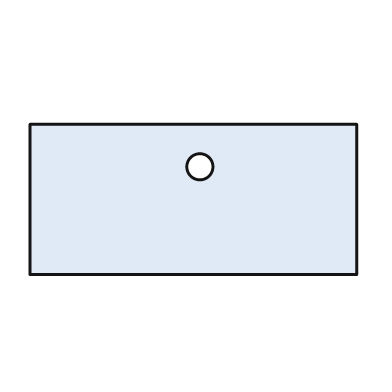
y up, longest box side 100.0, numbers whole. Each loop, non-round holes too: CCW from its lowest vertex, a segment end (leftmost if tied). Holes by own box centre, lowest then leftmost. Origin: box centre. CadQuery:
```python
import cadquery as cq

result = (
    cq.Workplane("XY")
    .moveTo(-50.0, -23.0)
    .lineTo(50.0, -23.0)
    .lineTo(50.0, 23.0)
    .lineTo(-50.0, 23.0)
    .close()
    .moveTo(2.0, 10.0)
    .circle(4.0)
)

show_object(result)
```